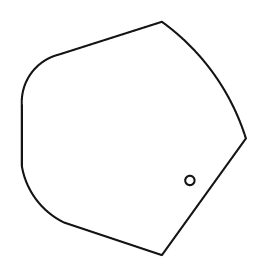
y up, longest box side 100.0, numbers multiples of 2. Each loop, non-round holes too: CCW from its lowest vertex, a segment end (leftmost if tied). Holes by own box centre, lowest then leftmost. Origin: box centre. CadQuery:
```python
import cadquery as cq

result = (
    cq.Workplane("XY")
    .moveTo(12.0, -50.0)
    .lineTo(48.0, 0.0)
    .threePointArc((34.0, 28.0), (12.0, 50.0))
    .lineTo(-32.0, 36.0)
    .threePointArc((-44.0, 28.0), (-48.0, 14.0))
    .lineTo(-48.0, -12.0)
    .threePointArc((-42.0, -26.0), (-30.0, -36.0))
    .close()
    .moveTo(24.0, -18.0)
    .circle(2.0)
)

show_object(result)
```